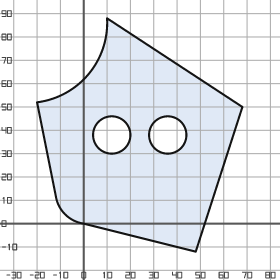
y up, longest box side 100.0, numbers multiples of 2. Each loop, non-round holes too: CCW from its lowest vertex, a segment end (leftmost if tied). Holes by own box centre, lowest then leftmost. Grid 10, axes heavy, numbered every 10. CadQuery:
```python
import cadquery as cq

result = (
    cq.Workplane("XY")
    .moveTo(48.0, -12.0)
    .lineTo(68.0, 50.0)
    .lineTo(10.0, 88.0)
    .threePointArc((2.0, 64.0), (-20.0, 52.0))
    .lineTo(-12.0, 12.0)
    .threePointArc((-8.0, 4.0), (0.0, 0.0))
    .close()
    .moveTo(12.0, 38.0)
    .circle(8.0)
    .moveTo(36.0, 38.0)
    .circle(8.0)
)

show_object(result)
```